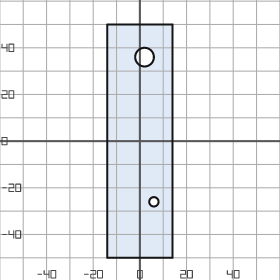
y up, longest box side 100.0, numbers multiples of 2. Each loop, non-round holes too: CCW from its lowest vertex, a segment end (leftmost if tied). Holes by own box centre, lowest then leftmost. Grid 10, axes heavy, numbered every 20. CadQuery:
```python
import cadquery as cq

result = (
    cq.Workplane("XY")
    .moveTo(-14.0, -50.0)
    .lineTo(14.0, -50.0)
    .lineTo(14.0, 50.0)
    .lineTo(-14.0, 50.0)
    .close()
    .moveTo(6.0, -26.0)
    .circle(2.0)
    .moveTo(2.0, 36.0)
    .circle(4.0)
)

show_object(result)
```